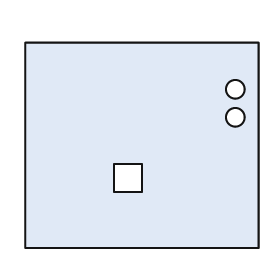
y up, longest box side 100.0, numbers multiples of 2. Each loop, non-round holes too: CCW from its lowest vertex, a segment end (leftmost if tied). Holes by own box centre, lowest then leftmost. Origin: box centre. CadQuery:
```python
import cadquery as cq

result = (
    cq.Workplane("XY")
    .moveTo(-50.0, -44.0)
    .lineTo(50.0, -44.0)
    .lineTo(50.0, 44.0)
    .lineTo(-50.0, 44.0)
    .close()
    .moveTo(-12.0, -20.0)
    .lineTo(0.0, -20.0)
    .lineTo(0.0, -8.0)
    .lineTo(-12.0, -8.0)
    .close()
    .moveTo(40.0, 12.0)
    .circle(4.0)
    .moveTo(40.0, 24.0)
    .circle(4.0)
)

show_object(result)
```